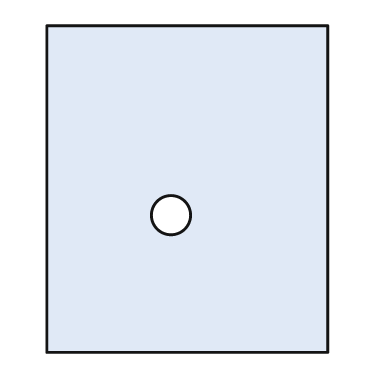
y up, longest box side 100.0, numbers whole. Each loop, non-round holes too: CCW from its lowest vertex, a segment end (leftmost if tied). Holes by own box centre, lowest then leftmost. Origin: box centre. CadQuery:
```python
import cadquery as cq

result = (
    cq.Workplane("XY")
    .moveTo(-43.0, -50.0)
    .lineTo(43.0, -50.0)
    .lineTo(43.0, 50.0)
    .lineTo(-43.0, 50.0)
    .close()
    .moveTo(-5.0, -8.0)
    .circle(6.0)
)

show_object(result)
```